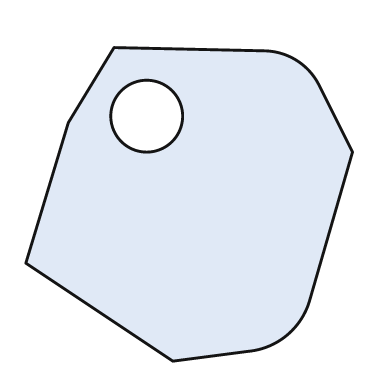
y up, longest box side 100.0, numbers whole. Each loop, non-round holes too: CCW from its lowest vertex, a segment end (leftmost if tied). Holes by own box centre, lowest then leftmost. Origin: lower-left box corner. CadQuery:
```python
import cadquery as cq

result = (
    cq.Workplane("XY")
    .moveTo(45.0, 0.0)
    .lineTo(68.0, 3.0)
    .threePointArc((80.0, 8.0), (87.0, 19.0))
    .lineTo(100.0, 64.0)
    .lineTo(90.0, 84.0)
    .threePointArc((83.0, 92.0), (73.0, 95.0))
    .lineTo(27.0, 96.0)
    .lineTo(13.0, 73.0)
    .lineTo(0.0, 30.0)
    .close()
    .moveTo(37.0, 75.0)
    .circle(11.0)
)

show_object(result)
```